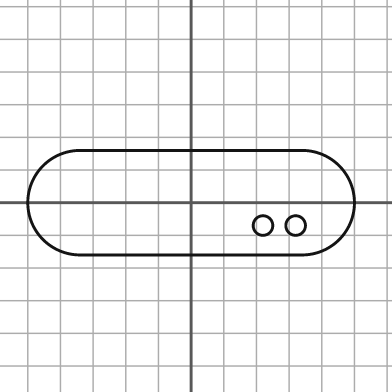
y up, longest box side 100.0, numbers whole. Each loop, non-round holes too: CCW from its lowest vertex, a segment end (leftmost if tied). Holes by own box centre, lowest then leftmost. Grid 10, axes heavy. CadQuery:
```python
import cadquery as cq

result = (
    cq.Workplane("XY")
    .moveTo(-34.0, -16.0)
    .lineTo(34.0, -16.0)
    .threePointArc((50.0, 0.0), (34.0, 16.0))
    .lineTo(-34.0, 16.0)
    .threePointArc((-50.0, 0.0), (-34.0, -16.0))
    .close()
    .moveTo(22.0, -7.0)
    .circle(3.0)
    .moveTo(32.0, -7.0)
    .circle(3.0)
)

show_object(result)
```